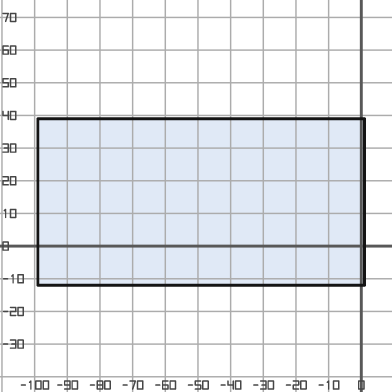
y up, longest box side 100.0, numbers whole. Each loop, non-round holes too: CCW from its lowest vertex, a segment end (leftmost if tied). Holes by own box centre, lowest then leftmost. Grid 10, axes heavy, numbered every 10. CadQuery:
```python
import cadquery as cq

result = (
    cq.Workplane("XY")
    .moveTo(-99.0, -12.0)
    .lineTo(1.0, -12.0)
    .lineTo(1.0, 39.0)
    .lineTo(-99.0, 39.0)
    .close()
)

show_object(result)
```